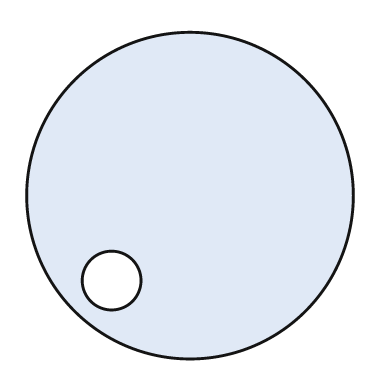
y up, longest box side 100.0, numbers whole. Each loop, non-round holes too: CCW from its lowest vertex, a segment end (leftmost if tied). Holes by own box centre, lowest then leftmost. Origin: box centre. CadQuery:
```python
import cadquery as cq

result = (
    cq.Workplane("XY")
    .moveTo(0.0, 0.0)
    .circle(50.0)
    .moveTo(-24.0, -26.0)
    .circle(9.0)
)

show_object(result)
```